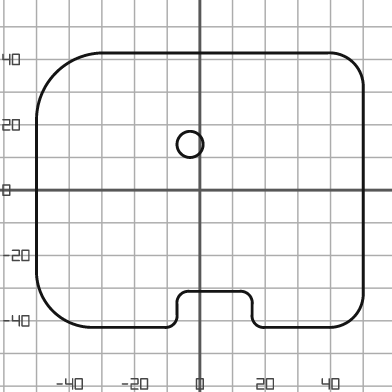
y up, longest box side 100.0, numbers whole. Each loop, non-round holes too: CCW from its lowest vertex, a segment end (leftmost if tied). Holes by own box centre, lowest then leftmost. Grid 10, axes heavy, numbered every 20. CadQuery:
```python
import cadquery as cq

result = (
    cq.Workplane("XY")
    .moveTo(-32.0, -42.0)
    .lineTo(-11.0, -42.0)
    .threePointArc((-8.0, -41.0), (-7.0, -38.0))
    .lineTo(-7.0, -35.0)
    .threePointArc((-6.0, -32.0), (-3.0, -31.0))
    .lineTo(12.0, -31.0)
    .threePointArc((15.0, -32.0), (16.0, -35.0))
    .lineTo(16.0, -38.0)
    .threePointArc((17.0, -41.0), (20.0, -42.0))
    .lineTo(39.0, -42.0)
    .threePointArc((47.0, -39.0), (50.0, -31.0))
    .lineTo(50.0, 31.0)
    .threePointArc((47.0, 39.0), (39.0, 42.0))
    .lineTo(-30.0, 42.0)
    .threePointArc((-44.0, 36.0), (-50.0, 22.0))
    .lineTo(-50.0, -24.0)
    .threePointArc((-45.0, -37.0), (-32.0, -42.0))
    .close()
    .moveTo(-3.0, 14.0)
    .circle(4.0)
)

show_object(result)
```